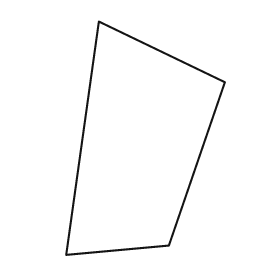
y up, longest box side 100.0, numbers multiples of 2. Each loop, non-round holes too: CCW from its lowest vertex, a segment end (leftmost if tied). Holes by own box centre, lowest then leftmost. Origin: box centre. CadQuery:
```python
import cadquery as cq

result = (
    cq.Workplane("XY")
    .moveTo(-34.0, -50.0)
    .lineTo(10.0, -46.0)
    .lineTo(34.0, 24.0)
    .lineTo(-20.0, 50.0)
    .close()
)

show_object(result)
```